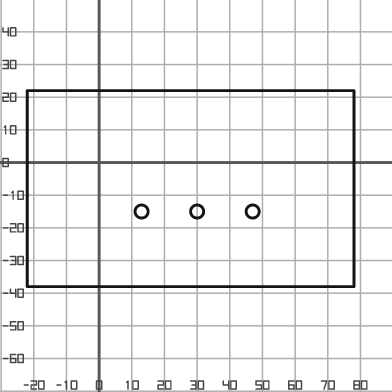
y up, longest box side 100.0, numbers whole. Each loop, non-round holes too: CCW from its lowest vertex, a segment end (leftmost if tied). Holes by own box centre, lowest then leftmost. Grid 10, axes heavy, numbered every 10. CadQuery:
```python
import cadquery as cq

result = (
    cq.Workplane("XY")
    .moveTo(-22.0, -38.0)
    .lineTo(78.0, -38.0)
    .lineTo(78.0, 22.0)
    .lineTo(-22.0, 22.0)
    .close()
    .moveTo(13.0, -15.0)
    .circle(2.0)
    .moveTo(30.0, -15.0)
    .circle(2.0)
    .moveTo(47.0, -15.0)
    .circle(2.0)
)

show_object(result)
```